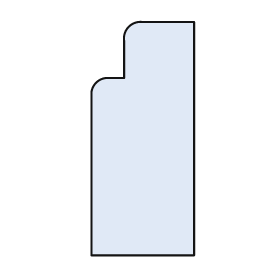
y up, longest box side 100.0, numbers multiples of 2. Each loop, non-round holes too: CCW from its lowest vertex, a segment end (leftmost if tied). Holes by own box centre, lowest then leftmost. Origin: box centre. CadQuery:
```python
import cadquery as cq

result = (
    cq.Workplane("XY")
    .moveTo(-22.0, -50.0)
    .lineTo(22.0, -50.0)
    .lineTo(22.0, 50.0)
    .lineTo(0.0, 50.0)
    .threePointArc((-6.0, 48.0), (-8.0, 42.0))
    .lineTo(-8.0, 26.0)
    .lineTo(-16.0, 26.0)
    .threePointArc((-20.0, 24.0), (-22.0, 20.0))
    .close()
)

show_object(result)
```